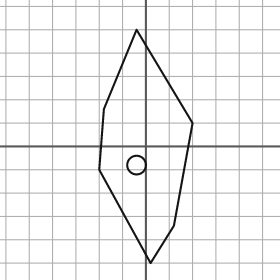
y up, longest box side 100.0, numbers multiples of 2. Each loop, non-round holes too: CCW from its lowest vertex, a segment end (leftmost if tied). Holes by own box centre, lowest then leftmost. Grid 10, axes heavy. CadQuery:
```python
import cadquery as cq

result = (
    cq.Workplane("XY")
    .moveTo(2.0, -50.0)
    .lineTo(12.0, -34.0)
    .lineTo(20.0, 10.0)
    .lineTo(-4.0, 50.0)
    .lineTo(-18.0, 16.0)
    .lineTo(-20.0, -10.0)
    .close()
    .moveTo(-4.0, -8.0)
    .circle(4.0)
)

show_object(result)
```